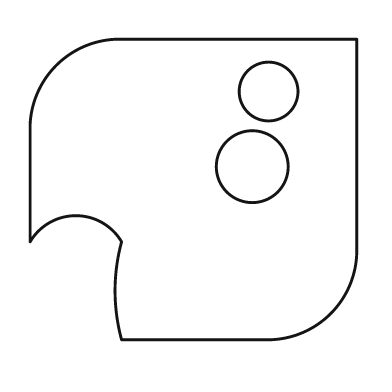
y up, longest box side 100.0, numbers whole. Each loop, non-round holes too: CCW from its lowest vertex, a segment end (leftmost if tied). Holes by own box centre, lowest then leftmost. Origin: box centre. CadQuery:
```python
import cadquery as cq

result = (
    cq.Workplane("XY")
    .moveTo(-22.0, -46.0)
    .lineTo(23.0, -46.0)
    .threePointArc((42.0, -38.0), (50.0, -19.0))
    .lineTo(50.0, 46.0)
    .lineTo(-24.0, 46.0)
    .threePointArc((-42.0, 38.0), (-50.0, 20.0))
    .lineTo(-50.0, -16.0)
    .threePointArc((-36.0, -8.0), (-22.0, -16.0))
    .threePointArc((-24.0, -31.0), (-22.0, -46.0))
    .close()
    .moveTo(18.0, 7.0)
    .circle(11.0)
    .moveTo(23.0, 30.0)
    .circle(9.0)
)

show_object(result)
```